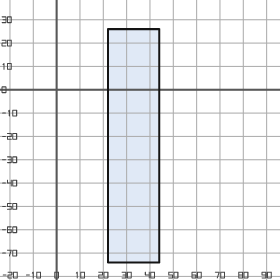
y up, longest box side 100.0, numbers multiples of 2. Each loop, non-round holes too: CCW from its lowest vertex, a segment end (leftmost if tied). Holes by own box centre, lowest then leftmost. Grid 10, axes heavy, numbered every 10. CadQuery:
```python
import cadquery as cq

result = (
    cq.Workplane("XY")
    .moveTo(22.0, -74.0)
    .lineTo(44.0, -74.0)
    .lineTo(44.0, 26.0)
    .lineTo(22.0, 26.0)
    .close()
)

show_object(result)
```